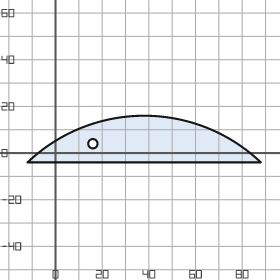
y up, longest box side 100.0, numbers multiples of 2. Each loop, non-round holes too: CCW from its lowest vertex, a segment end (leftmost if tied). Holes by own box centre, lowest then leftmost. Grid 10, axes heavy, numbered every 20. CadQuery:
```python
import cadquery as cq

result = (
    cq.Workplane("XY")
    .moveTo(-12.0, -4.0)
    .lineTo(88.0, -4.0)
    .threePointArc((38.0, 16.0), (-12.0, -4.0))
    .close()
    .moveTo(16.0, 4.0)
    .circle(2.0)
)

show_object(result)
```